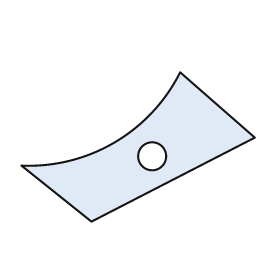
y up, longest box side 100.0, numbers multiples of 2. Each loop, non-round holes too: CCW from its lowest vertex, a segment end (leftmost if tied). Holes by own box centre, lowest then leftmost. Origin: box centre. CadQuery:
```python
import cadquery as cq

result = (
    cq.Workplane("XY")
    .moveTo(-20.0, -32.0)
    .lineTo(50.0, 4.0)
    .lineTo(18.0, 32.0)
    .threePointArc((-10.0, 2.0), (-50.0, -8.0))
    .close()
    .moveTo(6.0, -4.0)
    .circle(6.0)
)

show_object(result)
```